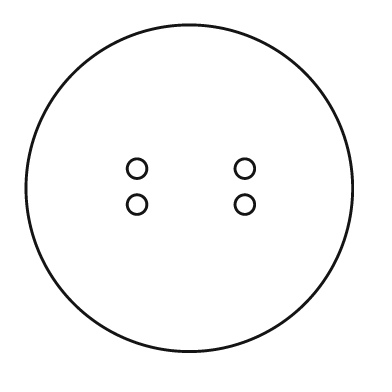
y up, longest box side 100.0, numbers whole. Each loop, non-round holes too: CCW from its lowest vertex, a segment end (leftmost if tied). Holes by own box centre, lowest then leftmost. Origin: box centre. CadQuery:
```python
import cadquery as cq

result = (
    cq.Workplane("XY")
    .moveTo(0.0, 0.0)
    .circle(50.0)
    .moveTo(-16.0, -5.0)
    .circle(3.0)
    .moveTo(17.0, -5.0)
    .circle(3.0)
    .moveTo(-16.0, 6.0)
    .circle(3.0)
    .moveTo(17.0, 6.0)
    .circle(3.0)
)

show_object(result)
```